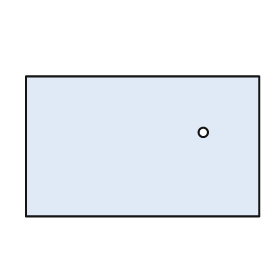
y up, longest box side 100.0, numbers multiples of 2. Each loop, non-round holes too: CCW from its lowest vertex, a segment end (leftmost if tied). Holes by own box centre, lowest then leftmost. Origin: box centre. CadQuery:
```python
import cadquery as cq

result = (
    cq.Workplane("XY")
    .moveTo(-50.0, -30.0)
    .lineTo(50.0, -30.0)
    .lineTo(50.0, 30.0)
    .lineTo(-50.0, 30.0)
    .close()
    .moveTo(26.0, 6.0)
    .circle(2.0)
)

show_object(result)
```